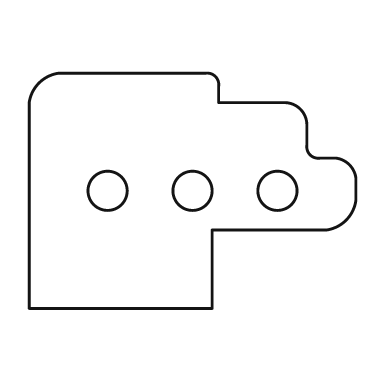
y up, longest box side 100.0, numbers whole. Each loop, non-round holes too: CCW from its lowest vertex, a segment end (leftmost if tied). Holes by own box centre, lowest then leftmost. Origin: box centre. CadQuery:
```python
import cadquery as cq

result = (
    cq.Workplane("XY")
    .moveTo(-50.0, -36.0)
    .lineTo(6.0, -36.0)
    .lineTo(6.0, -12.0)
    .lineTo(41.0, -12.0)
    .threePointArc((47.0, -9.0), (50.0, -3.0))
    .lineTo(50.0, 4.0)
    .threePointArc((48.0, 8.0), (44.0, 10.0))
    .lineTo(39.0, 10.0)
    .threePointArc((36.0, 11.0), (35.0, 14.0))
    .lineTo(35.0, 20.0)
    .threePointArc((33.0, 25.0), (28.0, 27.0))
    .lineTo(8.0, 27.0)
    .lineTo(8.0, 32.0)
    .threePointArc((7.0, 35.0), (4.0, 36.0))
    .lineTo(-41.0, 36.0)
    .threePointArc((-47.0, 33.0), (-50.0, 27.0))
    .close()
    .moveTo(-26.0, 0.0)
    .circle(6.0)
    .moveTo(0.0, 0.0)
    .circle(6.0)
    .moveTo(26.0, 0.0)
    .circle(6.0)
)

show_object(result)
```